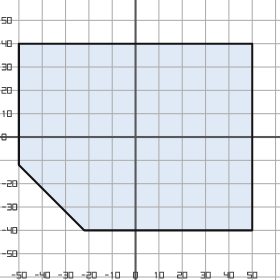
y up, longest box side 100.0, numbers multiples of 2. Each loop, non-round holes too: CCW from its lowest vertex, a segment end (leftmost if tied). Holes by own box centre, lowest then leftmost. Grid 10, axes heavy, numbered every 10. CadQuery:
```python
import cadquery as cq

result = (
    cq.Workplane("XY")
    .moveTo(-22.0, -40.0)
    .lineTo(50.0, -40.0)
    .lineTo(50.0, 40.0)
    .lineTo(-50.0, 40.0)
    .lineTo(-50.0, -12.0)
    .close()
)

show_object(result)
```